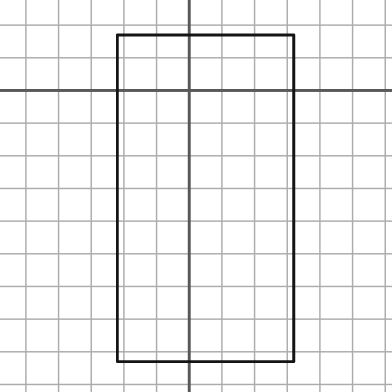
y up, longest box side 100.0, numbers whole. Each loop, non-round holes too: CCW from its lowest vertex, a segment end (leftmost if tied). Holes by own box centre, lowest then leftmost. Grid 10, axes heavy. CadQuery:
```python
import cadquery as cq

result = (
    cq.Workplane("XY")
    .moveTo(-22.0, -83.0)
    .lineTo(32.0, -83.0)
    .lineTo(32.0, 17.0)
    .lineTo(-22.0, 17.0)
    .close()
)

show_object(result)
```